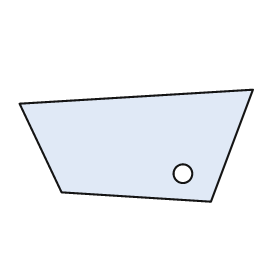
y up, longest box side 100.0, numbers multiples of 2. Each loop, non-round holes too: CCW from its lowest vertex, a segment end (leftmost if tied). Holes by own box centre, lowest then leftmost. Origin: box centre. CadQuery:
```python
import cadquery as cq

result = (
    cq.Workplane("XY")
    .moveTo(32.0, -24.0)
    .lineTo(50.0, 24.0)
    .lineTo(-50.0, 18.0)
    .lineTo(-32.0, -20.0)
    .close()
    .moveTo(20.0, -12.0)
    .circle(4.0)
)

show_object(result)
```